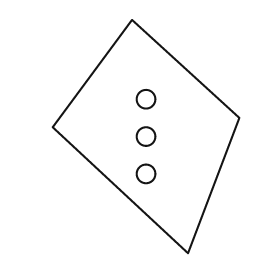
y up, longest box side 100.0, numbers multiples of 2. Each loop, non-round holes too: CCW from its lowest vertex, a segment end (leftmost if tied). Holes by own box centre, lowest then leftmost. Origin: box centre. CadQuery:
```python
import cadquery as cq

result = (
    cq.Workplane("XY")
    .moveTo(18.0, -50.0)
    .lineTo(40.0, 8.0)
    .lineTo(-6.0, 50.0)
    .lineTo(-40.0, 4.0)
    .close()
    .moveTo(0.0, -16.0)
    .circle(4.0)
    .moveTo(0.0, 0.0)
    .circle(4.0)
    .moveTo(0.0, 16.0)
    .circle(4.0)
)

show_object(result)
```